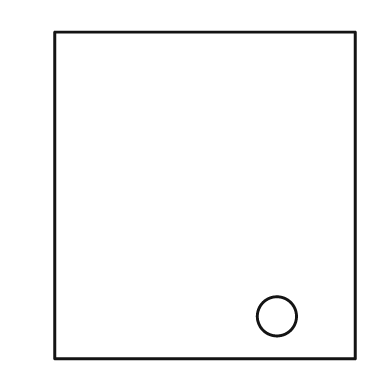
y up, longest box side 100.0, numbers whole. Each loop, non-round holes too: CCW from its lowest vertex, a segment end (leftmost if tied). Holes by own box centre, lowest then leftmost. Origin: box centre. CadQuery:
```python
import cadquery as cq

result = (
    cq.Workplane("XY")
    .moveTo(-46.0, -50.0)
    .lineTo(46.0, -50.0)
    .lineTo(46.0, 50.0)
    .lineTo(-46.0, 50.0)
    .close()
    .moveTo(22.0, -37.0)
    .circle(6.0)
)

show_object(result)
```